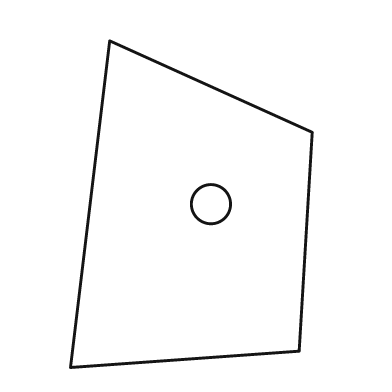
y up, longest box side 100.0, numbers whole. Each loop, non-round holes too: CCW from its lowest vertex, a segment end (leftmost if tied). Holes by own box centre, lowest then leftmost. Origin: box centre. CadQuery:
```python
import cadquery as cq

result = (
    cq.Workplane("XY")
    .moveTo(-37.0, -50.0)
    .lineTo(33.0, -45.0)
    .lineTo(37.0, 22.0)
    .lineTo(-25.0, 50.0)
    .close()
    .moveTo(6.0, 0.0)
    .circle(6.0)
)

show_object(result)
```